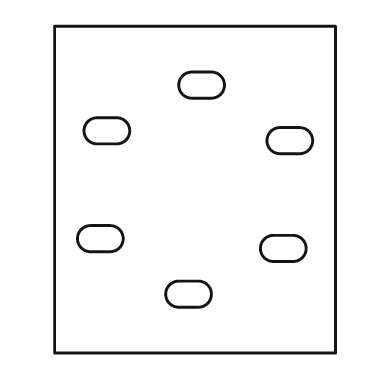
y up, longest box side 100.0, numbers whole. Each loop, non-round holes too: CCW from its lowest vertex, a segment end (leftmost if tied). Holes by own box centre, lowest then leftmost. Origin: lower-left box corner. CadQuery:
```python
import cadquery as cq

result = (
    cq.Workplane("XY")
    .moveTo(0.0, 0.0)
    .lineTo(86.0, 0.0)
    .lineTo(86.0, 100.0)
    .lineTo(0.0, 100.0)
    .close()
    .moveTo(38.0, 14.0)
    .lineTo(44.0, 14.0)
    .threePointArc((48.0, 18.0), (44.0, 22.0))
    .lineTo(38.0, 22.0)
    .threePointArc((34.0, 18.0), (38.0, 14.0))
    .close()
    .moveTo(67.0, 28.0)
    .lineTo(73.0, 28.0)
    .threePointArc((77.0, 32.0), (73.0, 36.0))
    .lineTo(67.0, 36.0)
    .threePointArc((63.0, 32.0), (67.0, 28.0))
    .close()
    .moveTo(11.0, 31.0)
    .lineTo(17.0, 31.0)
    .threePointArc((21.0, 35.0), (17.0, 39.0))
    .lineTo(11.0, 39.0)
    .threePointArc((7.0, 35.0), (11.0, 31.0))
    .close()
    .moveTo(69.0, 61.0)
    .lineTo(75.0, 61.0)
    .threePointArc((79.0, 65.0), (75.0, 69.0))
    .lineTo(69.0, 69.0)
    .threePointArc((65.0, 65.0), (69.0, 61.0))
    .close()
    .moveTo(13.0, 64.0)
    .lineTo(19.0, 64.0)
    .threePointArc((23.0, 68.0), (19.0, 72.0))
    .lineTo(13.0, 72.0)
    .threePointArc((9.0, 68.0), (13.0, 64.0))
    .close()
    .moveTo(42.0, 78.0)
    .lineTo(48.0, 78.0)
    .threePointArc((52.0, 82.0), (48.0, 86.0))
    .lineTo(42.0, 86.0)
    .threePointArc((38.0, 82.0), (42.0, 78.0))
    .close()
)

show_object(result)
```